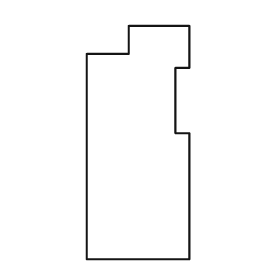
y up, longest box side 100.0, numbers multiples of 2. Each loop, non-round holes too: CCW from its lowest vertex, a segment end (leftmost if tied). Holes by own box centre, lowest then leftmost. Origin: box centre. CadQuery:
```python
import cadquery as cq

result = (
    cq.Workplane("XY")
    .moveTo(-22.0, -50.0)
    .lineTo(22.0, -50.0)
    .lineTo(22.0, 4.0)
    .lineTo(16.0, 4.0)
    .lineTo(16.0, 32.0)
    .lineTo(22.0, 32.0)
    .lineTo(22.0, 50.0)
    .lineTo(-4.0, 50.0)
    .lineTo(-4.0, 38.0)
    .lineTo(-22.0, 38.0)
    .close()
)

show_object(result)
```